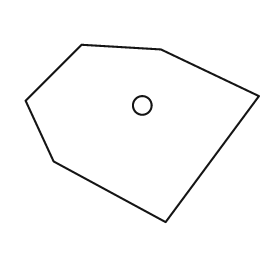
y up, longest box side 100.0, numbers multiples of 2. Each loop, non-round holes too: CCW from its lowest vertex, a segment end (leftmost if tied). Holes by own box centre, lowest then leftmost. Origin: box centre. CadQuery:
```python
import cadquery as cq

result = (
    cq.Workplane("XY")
    .moveTo(10.0, -38.0)
    .lineTo(50.0, 16.0)
    .lineTo(8.0, 36.0)
    .lineTo(-26.0, 38.0)
    .lineTo(-50.0, 14.0)
    .lineTo(-38.0, -12.0)
    .close()
    .moveTo(0.0, 12.0)
    .circle(4.0)
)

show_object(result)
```